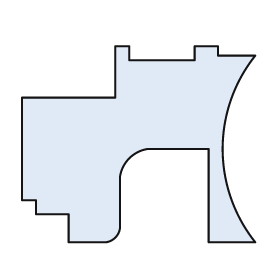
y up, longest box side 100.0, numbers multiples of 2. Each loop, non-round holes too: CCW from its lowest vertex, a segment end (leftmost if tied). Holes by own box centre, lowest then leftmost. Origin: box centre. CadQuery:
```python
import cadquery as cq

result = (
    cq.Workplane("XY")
    .moveTo(-30.0, -42.0)
    .lineTo(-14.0, -42.0)
    .threePointArc((-10.0, -40.0), (-8.0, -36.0))
    .lineTo(-8.0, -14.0)
    .threePointArc((-4.0, -6.0), (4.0, -2.0))
    .lineTo(30.0, -2.0)
    .lineTo(30.0, -42.0)
    .lineTo(50.0, -42.0)
    .threePointArc((36.0, -2.0), (50.0, 38.0))
    .lineTo(34.0, 38.0)
    .lineTo(34.0, 42.0)
    .lineTo(24.0, 42.0)
    .lineTo(24.0, 36.0)
    .lineTo(-4.0, 36.0)
    .lineTo(-4.0, 42.0)
    .lineTo(-10.0, 42.0)
    .lineTo(-10.0, 20.0)
    .lineTo(-50.0, 20.0)
    .lineTo(-50.0, -24.0)
    .lineTo(-44.0, -24.0)
    .lineTo(-44.0, -30.0)
    .lineTo(-30.0, -30.0)
    .close()
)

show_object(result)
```